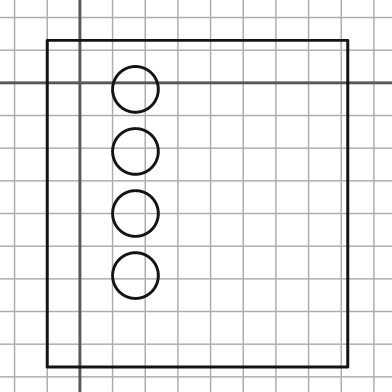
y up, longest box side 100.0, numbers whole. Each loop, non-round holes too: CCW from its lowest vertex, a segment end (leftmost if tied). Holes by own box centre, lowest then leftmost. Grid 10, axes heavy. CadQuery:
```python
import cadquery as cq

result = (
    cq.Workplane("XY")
    .moveTo(-10.0, -87.0)
    .lineTo(82.0, -87.0)
    .lineTo(82.0, 13.0)
    .lineTo(-10.0, 13.0)
    .close()
    .moveTo(17.0, -59.0)
    .circle(7.0)
    .moveTo(17.0, -40.0)
    .circle(7.0)
    .moveTo(17.0, -21.0)
    .circle(7.0)
    .moveTo(17.0, -2.0)
    .circle(7.0)
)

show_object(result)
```